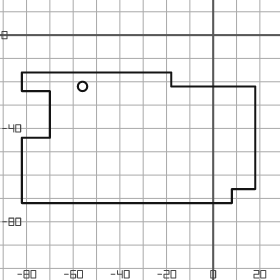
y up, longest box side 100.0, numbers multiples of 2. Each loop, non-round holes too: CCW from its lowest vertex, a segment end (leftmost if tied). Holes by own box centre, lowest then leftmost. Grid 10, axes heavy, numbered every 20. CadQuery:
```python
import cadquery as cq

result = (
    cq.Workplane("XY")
    .moveTo(-82.0, -72.0)
    .lineTo(8.0, -72.0)
    .lineTo(8.0, -66.0)
    .lineTo(18.0, -66.0)
    .lineTo(18.0, -22.0)
    .lineTo(-18.0, -22.0)
    .lineTo(-18.0, -16.0)
    .lineTo(-82.0, -16.0)
    .lineTo(-82.0, -24.0)
    .lineTo(-70.0, -24.0)
    .lineTo(-70.0, -44.0)
    .lineTo(-82.0, -44.0)
    .close()
    .moveTo(-56.0, -22.0)
    .circle(2.0)
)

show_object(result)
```